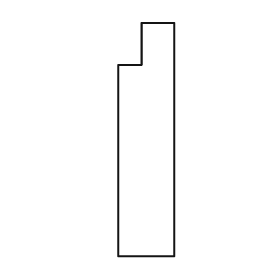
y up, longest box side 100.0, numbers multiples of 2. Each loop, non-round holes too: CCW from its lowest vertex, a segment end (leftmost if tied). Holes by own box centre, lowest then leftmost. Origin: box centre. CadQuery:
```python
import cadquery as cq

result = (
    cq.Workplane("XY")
    .moveTo(-12.0, -50.0)
    .lineTo(12.0, -50.0)
    .lineTo(12.0, 50.0)
    .lineTo(-2.0, 50.0)
    .lineTo(-2.0, 32.0)
    .lineTo(-12.0, 32.0)
    .close()
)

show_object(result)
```